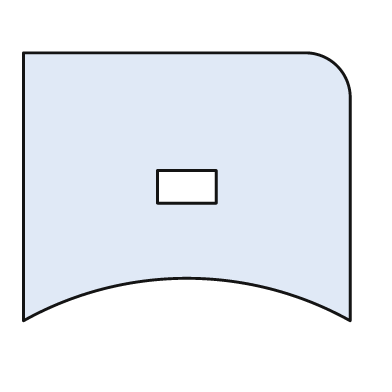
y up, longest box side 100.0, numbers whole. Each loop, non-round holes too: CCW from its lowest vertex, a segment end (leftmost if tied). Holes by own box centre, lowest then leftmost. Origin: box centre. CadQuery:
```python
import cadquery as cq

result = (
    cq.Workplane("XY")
    .moveTo(-50.0, -41.0)
    .threePointArc((0.0, -28.0), (50.0, -41.0))
    .lineTo(50.0, 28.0)
    .threePointArc((46.0, 37.0), (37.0, 41.0))
    .lineTo(-50.0, 41.0)
    .close()
    .moveTo(-9.0, -5.0)
    .lineTo(9.0, -5.0)
    .lineTo(9.0, 5.0)
    .lineTo(-9.0, 5.0)
    .close()
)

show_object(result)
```